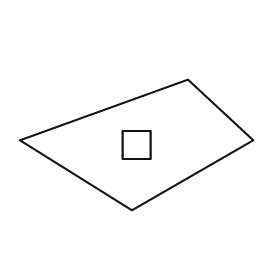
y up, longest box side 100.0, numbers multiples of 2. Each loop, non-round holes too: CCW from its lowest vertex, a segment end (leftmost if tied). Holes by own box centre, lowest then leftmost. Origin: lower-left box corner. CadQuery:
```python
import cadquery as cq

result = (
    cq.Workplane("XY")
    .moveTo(48.0, 0.0)
    .lineTo(100.0, 30.0)
    .lineTo(72.0, 56.0)
    .lineTo(0.0, 30.0)
    .close()
    .moveTo(44.0, 22.0)
    .lineTo(56.0, 22.0)
    .lineTo(56.0, 34.0)
    .lineTo(44.0, 34.0)
    .close()
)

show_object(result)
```